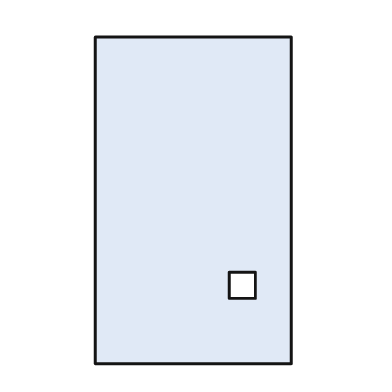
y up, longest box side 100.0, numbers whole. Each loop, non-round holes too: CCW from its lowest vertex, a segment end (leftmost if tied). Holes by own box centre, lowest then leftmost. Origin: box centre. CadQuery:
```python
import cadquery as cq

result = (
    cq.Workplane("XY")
    .moveTo(-30.0, -50.0)
    .lineTo(30.0, -50.0)
    .lineTo(30.0, 50.0)
    .lineTo(-30.0, 50.0)
    .close()
    .moveTo(11.0, -30.0)
    .lineTo(19.0, -30.0)
    .lineTo(19.0, -22.0)
    .lineTo(11.0, -22.0)
    .close()
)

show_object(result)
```